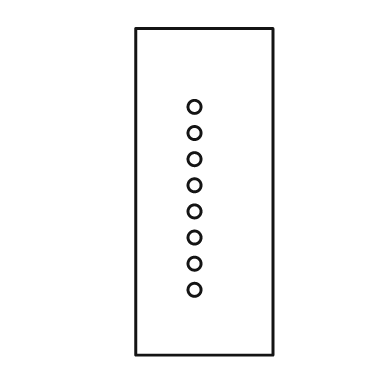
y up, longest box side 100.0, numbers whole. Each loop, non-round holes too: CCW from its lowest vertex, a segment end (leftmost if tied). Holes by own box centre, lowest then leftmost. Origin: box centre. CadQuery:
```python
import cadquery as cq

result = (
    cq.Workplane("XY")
    .moveTo(-21.0, -50.0)
    .lineTo(21.0, -50.0)
    .lineTo(21.0, 50.0)
    .lineTo(-21.0, 50.0)
    .close()
    .moveTo(-3.0, -30.0)
    .circle(2.0)
    .moveTo(-3.0, -22.0)
    .circle(2.0)
    .moveTo(-3.0, -14.0)
    .circle(2.0)
    .moveTo(-3.0, -6.0)
    .circle(2.0)
    .moveTo(-3.0, 2.0)
    .circle(2.0)
    .moveTo(-3.0, 10.0)
    .circle(2.0)
    .moveTo(-3.0, 18.0)
    .circle(2.0)
    .moveTo(-3.0, 26.0)
    .circle(2.0)
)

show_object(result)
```